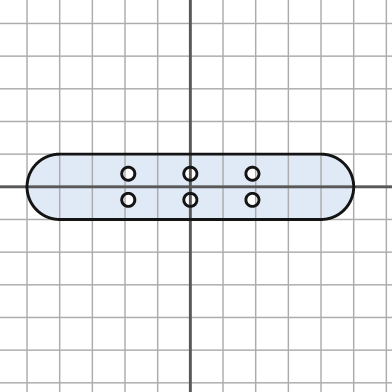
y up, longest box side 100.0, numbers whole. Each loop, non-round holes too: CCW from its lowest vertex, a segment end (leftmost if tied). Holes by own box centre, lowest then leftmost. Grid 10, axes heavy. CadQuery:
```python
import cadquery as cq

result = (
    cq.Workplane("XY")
    .moveTo(-40.0, -10.0)
    .lineTo(40.0, -10.0)
    .threePointArc((50.0, 0.0), (40.0, 10.0))
    .lineTo(-40.0, 10.0)
    .threePointArc((-50.0, 0.0), (-40.0, -10.0))
    .close()
    .moveTo(-19.0, -4.0)
    .circle(2.0)
    .moveTo(0.0, -4.0)
    .circle(2.0)
    .moveTo(19.0, -4.0)
    .circle(2.0)
    .moveTo(-19.0, 4.0)
    .circle(2.0)
    .moveTo(0.0, 4.0)
    .circle(2.0)
    .moveTo(19.0, 4.0)
    .circle(2.0)
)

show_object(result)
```